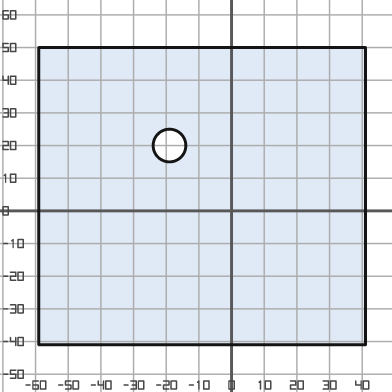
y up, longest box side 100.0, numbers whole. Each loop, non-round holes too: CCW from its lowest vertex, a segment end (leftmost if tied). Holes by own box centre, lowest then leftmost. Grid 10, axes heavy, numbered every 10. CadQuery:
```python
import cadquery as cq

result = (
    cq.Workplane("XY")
    .moveTo(-59.0, -41.0)
    .lineTo(41.0, -41.0)
    .lineTo(41.0, 50.0)
    .lineTo(-59.0, 50.0)
    .close()
    .moveTo(-19.0, 20.0)
    .circle(5.0)
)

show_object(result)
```